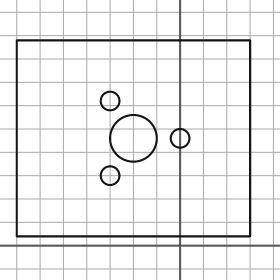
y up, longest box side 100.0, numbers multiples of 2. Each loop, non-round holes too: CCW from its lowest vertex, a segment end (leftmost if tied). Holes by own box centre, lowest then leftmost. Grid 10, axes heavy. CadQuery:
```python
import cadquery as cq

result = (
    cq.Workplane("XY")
    .moveTo(-70.0, 4.0)
    .lineTo(30.0, 4.0)
    .lineTo(30.0, 88.0)
    .lineTo(-70.0, 88.0)
    .close()
    .moveTo(-30.0, 30.0)
    .circle(4.0)
    .moveTo(-20.0, 46.0)
    .circle(10.0)
    .moveTo(0.0, 46.0)
    .circle(4.0)
    .moveTo(-30.0, 62.0)
    .circle(4.0)
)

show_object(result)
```